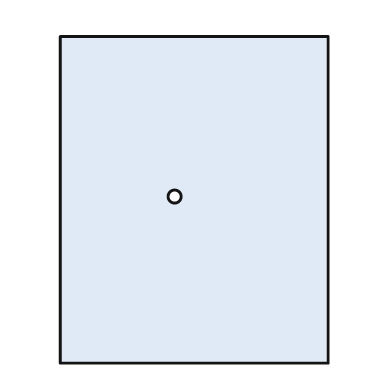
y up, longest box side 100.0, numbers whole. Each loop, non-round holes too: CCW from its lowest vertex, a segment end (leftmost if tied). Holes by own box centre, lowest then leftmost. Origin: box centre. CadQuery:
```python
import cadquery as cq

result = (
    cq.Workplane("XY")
    .moveTo(-41.0, -50.0)
    .lineTo(41.0, -50.0)
    .lineTo(41.0, 50.0)
    .lineTo(-41.0, 50.0)
    .close()
    .moveTo(-6.0, 1.0)
    .circle(2.0)
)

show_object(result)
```